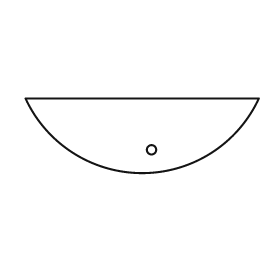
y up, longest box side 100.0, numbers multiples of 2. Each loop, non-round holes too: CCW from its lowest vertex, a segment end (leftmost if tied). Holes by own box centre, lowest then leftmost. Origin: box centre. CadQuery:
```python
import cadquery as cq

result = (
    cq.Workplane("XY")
    .moveTo(-50.0, 16.0)
    .threePointArc((0.0, -16.0), (50.0, 16.0))
    .close()
    .moveTo(4.0, -6.0)
    .circle(2.0)
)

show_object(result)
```